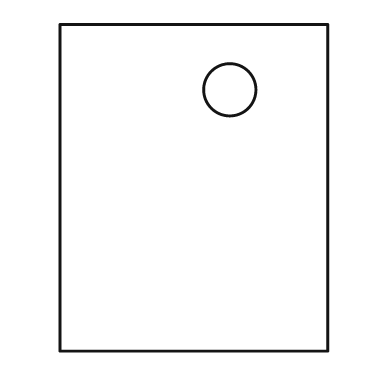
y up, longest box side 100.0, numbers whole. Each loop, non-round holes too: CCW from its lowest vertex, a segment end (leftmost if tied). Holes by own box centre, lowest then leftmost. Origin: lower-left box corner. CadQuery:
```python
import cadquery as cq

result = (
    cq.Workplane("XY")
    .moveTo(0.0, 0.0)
    .lineTo(82.0, 0.0)
    .lineTo(82.0, 100.0)
    .lineTo(0.0, 100.0)
    .close()
    .moveTo(52.0, 80.0)
    .circle(8.0)
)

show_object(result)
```